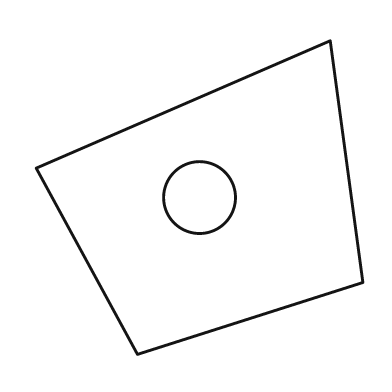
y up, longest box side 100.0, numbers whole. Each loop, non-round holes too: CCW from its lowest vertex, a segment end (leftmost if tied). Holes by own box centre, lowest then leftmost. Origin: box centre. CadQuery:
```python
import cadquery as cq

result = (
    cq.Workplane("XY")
    .moveTo(-19.0, -48.0)
    .lineTo(50.0, -26.0)
    .lineTo(40.0, 48.0)
    .lineTo(-50.0, 9.0)
    .close()
    .moveTo(0.0, 0.0)
    .circle(11.0)
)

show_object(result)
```